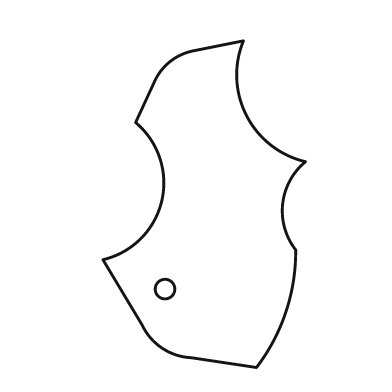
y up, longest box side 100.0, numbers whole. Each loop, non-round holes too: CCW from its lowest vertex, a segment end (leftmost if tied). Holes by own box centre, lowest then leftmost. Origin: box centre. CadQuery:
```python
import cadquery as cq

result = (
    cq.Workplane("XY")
    .moveTo(16.0, -50.0)
    .threePointArc((25.0, -33.0), (28.0, -14.0))
    .threePointArc((24.0, 0.0), (31.0, 13.0))
    .threePointArc((13.0, 27.0), (12.0, 50.0))
    .lineTo(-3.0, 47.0)
    .threePointArc((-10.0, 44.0), (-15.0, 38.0))
    .lineTo(-21.0, 25.0)
    .threePointArc((-13.0, 1.0), (-31.0, -17.0))
    .lineTo(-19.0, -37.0)
    .threePointArc((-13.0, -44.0), (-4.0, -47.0))
    .close()
    .moveTo(-12.0, -26.0)
    .circle(3.0)
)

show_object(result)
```